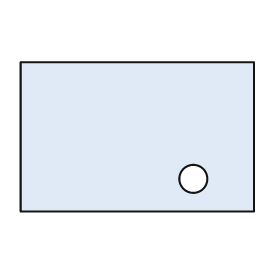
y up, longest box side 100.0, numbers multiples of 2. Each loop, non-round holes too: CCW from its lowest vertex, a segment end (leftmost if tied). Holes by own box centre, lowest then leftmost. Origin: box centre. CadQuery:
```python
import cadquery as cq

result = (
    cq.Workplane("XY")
    .moveTo(-50.0, -32.0)
    .lineTo(50.0, -32.0)
    .lineTo(50.0, 32.0)
    .lineTo(-50.0, 32.0)
    .close()
    .moveTo(24.0, -18.0)
    .circle(6.0)
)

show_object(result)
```